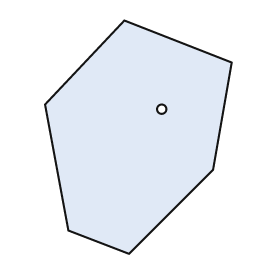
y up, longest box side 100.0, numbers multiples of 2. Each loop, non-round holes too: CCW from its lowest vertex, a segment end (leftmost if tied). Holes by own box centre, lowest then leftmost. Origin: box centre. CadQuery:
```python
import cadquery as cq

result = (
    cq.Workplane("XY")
    .moveTo(-4.0, -50.0)
    .lineTo(32.0, -14.0)
    .lineTo(40.0, 32.0)
    .lineTo(-6.0, 50.0)
    .lineTo(-40.0, 14.0)
    .lineTo(-30.0, -40.0)
    .close()
    .moveTo(10.0, 12.0)
    .circle(2.0)
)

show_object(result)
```